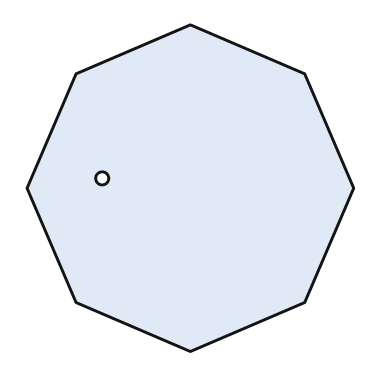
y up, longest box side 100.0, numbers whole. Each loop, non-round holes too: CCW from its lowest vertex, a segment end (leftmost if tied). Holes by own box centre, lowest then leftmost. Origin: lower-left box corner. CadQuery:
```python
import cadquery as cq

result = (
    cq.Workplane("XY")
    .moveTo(50.0, 0.0)
    .lineTo(85.0, 15.0)
    .lineTo(100.0, 50.0)
    .lineTo(85.0, 85.0)
    .lineTo(50.0, 100.0)
    .lineTo(15.0, 85.0)
    .lineTo(0.0, 50.0)
    .lineTo(15.0, 15.0)
    .close()
    .moveTo(23.0, 53.0)
    .circle(2.0)
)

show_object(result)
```